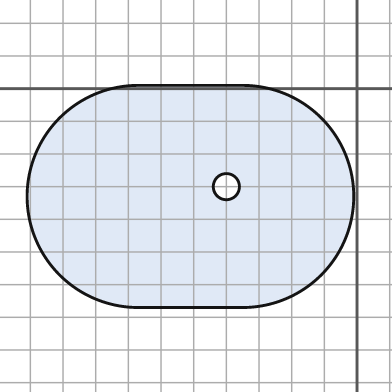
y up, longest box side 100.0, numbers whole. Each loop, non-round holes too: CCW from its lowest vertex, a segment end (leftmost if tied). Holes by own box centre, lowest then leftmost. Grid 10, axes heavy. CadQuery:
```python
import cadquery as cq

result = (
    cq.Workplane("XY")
    .moveTo(-67.0, -67.0)
    .lineTo(-35.0, -67.0)
    .threePointArc((-1.0, -33.0), (-35.0, 1.0))
    .lineTo(-67.0, 1.0)
    .threePointArc((-101.0, -33.0), (-67.0, -67.0))
    .close()
    .moveTo(-40.0, -30.0)
    .circle(4.0)
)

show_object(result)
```